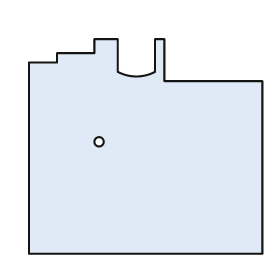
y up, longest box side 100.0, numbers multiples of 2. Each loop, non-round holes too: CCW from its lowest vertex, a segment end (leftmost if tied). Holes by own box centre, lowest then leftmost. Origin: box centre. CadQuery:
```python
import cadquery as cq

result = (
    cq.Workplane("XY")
    .moveTo(-50.0, -46.0)
    .lineTo(50.0, -46.0)
    .lineTo(50.0, 28.0)
    .lineTo(8.0, 28.0)
    .lineTo(8.0, 46.0)
    .lineTo(4.0, 46.0)
    .lineTo(4.0, 32.0)
    .threePointArc((-4.0, 30.0), (-12.0, 32.0))
    .lineTo(-12.0, 46.0)
    .lineTo(-22.0, 46.0)
    .lineTo(-22.0, 40.0)
    .lineTo(-38.0, 40.0)
    .lineTo(-38.0, 36.0)
    .lineTo(-50.0, 36.0)
    .close()
    .moveTo(-20.0, 2.0)
    .circle(2.0)
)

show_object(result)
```